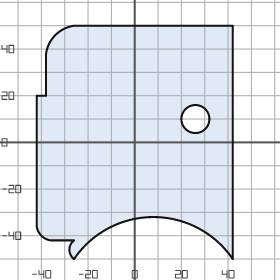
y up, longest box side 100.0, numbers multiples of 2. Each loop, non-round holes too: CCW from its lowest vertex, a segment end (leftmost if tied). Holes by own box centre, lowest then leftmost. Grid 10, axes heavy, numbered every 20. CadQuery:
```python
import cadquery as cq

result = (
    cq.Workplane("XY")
    .moveTo(-26.0, -50.0)
    .threePointArc((8.0, -32.0), (42.0, -50.0))
    .lineTo(42.0, 50.0)
    .lineTo(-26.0, 50.0)
    .threePointArc((-34.0, 46.0), (-38.0, 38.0))
    .lineTo(-38.0, 20.0)
    .lineTo(-42.0, 20.0)
    .lineTo(-42.0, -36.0)
    .threePointArc((-40.0, -40.0), (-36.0, -42.0))
    .lineTo(-26.0, -42.0)
    .threePointArc((-28.0, -46.0), (-26.0, -50.0))
    .close()
    .moveTo(26.0, 10.0)
    .circle(6.0)
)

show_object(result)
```